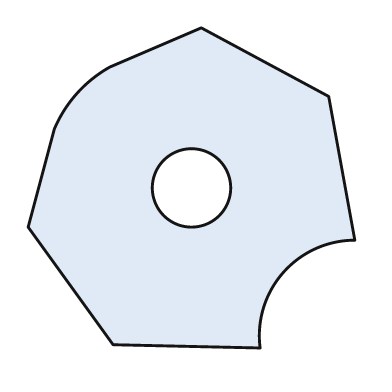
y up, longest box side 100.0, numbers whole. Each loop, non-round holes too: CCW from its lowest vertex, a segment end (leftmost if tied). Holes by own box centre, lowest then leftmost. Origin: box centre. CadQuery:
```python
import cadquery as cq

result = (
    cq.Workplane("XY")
    .moveTo(21.0, -49.0)
    .threePointArc((28.0, -26.0), (50.0, -16.0))
    .lineTo(42.0, 28.0)
    .lineTo(3.0, 49.0)
    .lineTo(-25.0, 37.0)
    .threePointArc((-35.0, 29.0), (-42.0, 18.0))
    .lineTo(-50.0, -12.0)
    .lineTo(-24.0, -48.0)
    .close()
    .moveTo(0.0, 0.0)
    .circle(12.0)
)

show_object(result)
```